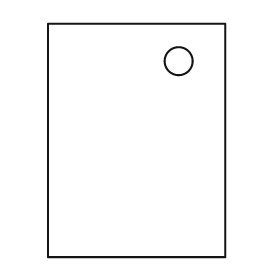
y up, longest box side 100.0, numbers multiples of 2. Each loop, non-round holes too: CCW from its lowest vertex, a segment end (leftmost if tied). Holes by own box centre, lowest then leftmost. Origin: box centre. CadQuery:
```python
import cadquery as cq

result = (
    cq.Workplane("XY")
    .moveTo(-38.0, -50.0)
    .lineTo(38.0, -50.0)
    .lineTo(38.0, 50.0)
    .lineTo(-38.0, 50.0)
    .close()
    .moveTo(18.0, 34.0)
    .circle(6.0)
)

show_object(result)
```